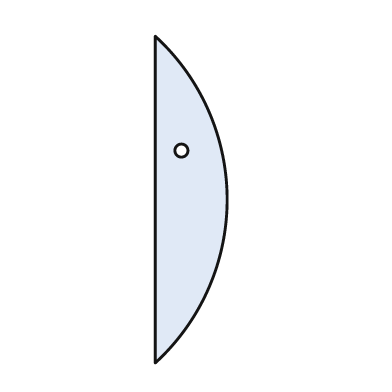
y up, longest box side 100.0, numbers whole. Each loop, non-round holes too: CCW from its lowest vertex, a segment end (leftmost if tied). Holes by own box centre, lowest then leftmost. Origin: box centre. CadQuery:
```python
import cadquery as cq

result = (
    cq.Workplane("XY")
    .moveTo(-11.0, -50.0)
    .threePointArc((11.0, 0.0), (-11.0, 50.0))
    .close()
    .moveTo(-3.0, 15.0)
    .circle(2.0)
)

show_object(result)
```